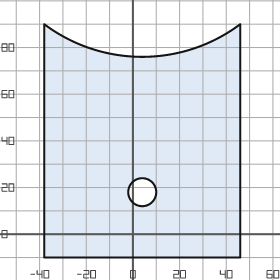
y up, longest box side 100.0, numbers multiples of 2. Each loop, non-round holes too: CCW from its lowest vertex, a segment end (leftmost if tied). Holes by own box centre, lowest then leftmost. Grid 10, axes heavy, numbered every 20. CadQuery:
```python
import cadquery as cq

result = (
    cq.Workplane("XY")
    .moveTo(-38.0, -10.0)
    .lineTo(46.0, -10.0)
    .lineTo(46.0, 90.0)
    .threePointArc((4.0, 76.0), (-38.0, 90.0))
    .close()
    .moveTo(4.0, 18.0)
    .circle(6.0)
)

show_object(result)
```